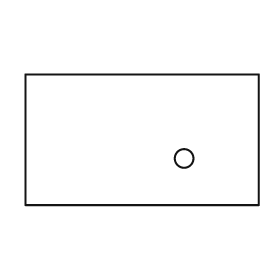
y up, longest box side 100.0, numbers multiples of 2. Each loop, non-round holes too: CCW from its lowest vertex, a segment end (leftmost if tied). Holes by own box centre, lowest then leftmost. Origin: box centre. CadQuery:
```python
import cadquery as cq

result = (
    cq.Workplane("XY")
    .moveTo(-50.0, -28.0)
    .lineTo(50.0, -28.0)
    .lineTo(50.0, 28.0)
    .lineTo(-50.0, 28.0)
    .close()
    .moveTo(18.0, -8.0)
    .circle(4.0)
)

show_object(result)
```